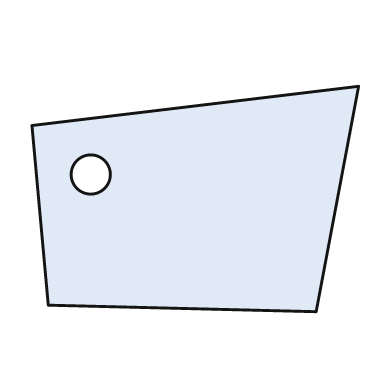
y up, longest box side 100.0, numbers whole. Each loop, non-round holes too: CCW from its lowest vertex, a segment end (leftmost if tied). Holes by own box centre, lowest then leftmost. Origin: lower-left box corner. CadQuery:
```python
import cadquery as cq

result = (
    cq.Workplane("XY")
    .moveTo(87.0, 0.0)
    .lineTo(100.0, 69.0)
    .lineTo(0.0, 57.0)
    .lineTo(5.0, 2.0)
    .close()
    .moveTo(18.0, 42.0)
    .circle(6.0)
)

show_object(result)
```